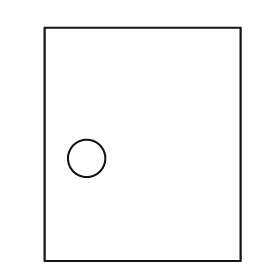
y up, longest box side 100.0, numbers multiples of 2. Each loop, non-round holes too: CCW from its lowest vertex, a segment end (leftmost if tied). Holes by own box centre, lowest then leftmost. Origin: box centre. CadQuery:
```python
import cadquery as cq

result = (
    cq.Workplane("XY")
    .moveTo(-42.0, -50.0)
    .lineTo(42.0, -50.0)
    .lineTo(42.0, 50.0)
    .lineTo(-42.0, 50.0)
    .close()
    .moveTo(-24.0, -6.0)
    .circle(8.0)
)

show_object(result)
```